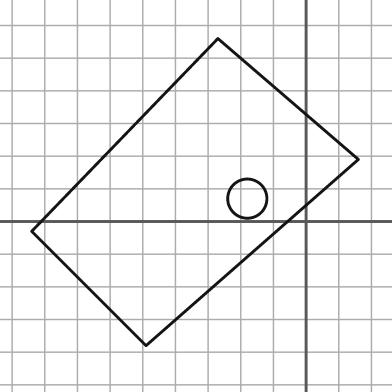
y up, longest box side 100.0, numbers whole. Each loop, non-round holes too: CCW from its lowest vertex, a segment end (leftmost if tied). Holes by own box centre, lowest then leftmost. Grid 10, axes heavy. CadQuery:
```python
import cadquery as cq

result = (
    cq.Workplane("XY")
    .moveTo(-49.0, -38.0)
    .lineTo(16.0, 19.0)
    .lineTo(-27.0, 56.0)
    .lineTo(-84.0, -3.0)
    .close()
    .moveTo(-18.0, 7.0)
    .circle(6.0)
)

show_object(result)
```